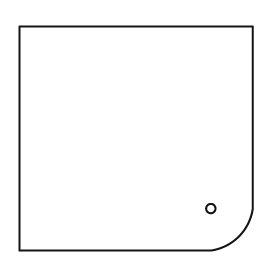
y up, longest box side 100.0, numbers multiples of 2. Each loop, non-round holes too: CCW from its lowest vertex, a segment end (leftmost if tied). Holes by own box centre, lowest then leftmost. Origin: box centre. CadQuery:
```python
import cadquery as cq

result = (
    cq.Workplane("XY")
    .moveTo(-50.0, -48.0)
    .lineTo(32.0, -48.0)
    .threePointArc((44.0, -42.0), (50.0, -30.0))
    .lineTo(50.0, 48.0)
    .lineTo(-50.0, 48.0)
    .close()
    .moveTo(32.0, -30.0)
    .circle(2.0)
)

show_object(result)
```